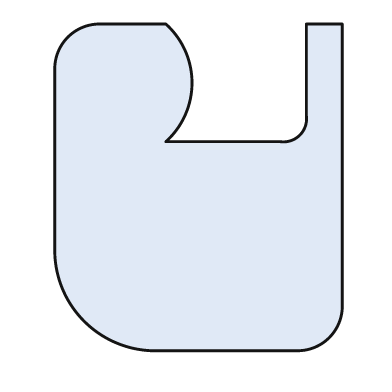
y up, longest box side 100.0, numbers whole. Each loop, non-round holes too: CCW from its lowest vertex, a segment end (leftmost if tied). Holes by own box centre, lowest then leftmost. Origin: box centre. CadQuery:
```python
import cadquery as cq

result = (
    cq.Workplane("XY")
    .moveTo(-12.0, -50.0)
    .lineTo(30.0, -50.0)
    .threePointArc((40.0, -46.0), (44.0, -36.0))
    .lineTo(44.0, 50.0)
    .lineTo(33.0, 50.0)
    .lineTo(33.0, 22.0)
    .threePointArc((31.0, 16.0), (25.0, 14.0))
    .lineTo(-10.0, 14.0)
    .threePointArc((-2.0, 32.0), (-10.0, 50.0))
    .lineTo(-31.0, 50.0)
    .threePointArc((-40.0, 46.0), (-44.0, 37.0))
    .lineTo(-44.0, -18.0)
    .threePointArc((-35.0, -41.0), (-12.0, -50.0))
    .close()
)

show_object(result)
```